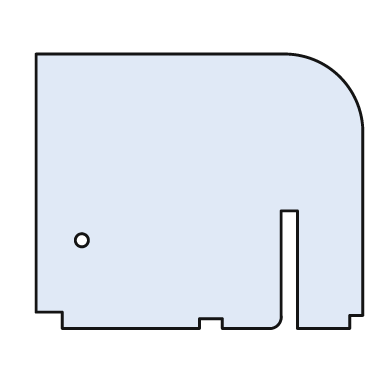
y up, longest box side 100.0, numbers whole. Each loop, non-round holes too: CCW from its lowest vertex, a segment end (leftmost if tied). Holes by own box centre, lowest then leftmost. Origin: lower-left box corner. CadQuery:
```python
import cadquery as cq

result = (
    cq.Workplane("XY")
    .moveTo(8.0, 0.0)
    .lineTo(50.0, 0.0)
    .lineTo(50.0, 3.0)
    .lineTo(57.0, 3.0)
    .lineTo(57.0, 0.0)
    .lineTo(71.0, 0.0)
    .threePointArc((74.0, 1.0), (75.0, 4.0))
    .lineTo(75.0, 36.0)
    .lineTo(80.0, 36.0)
    .lineTo(80.0, 0.0)
    .lineTo(96.0, 0.0)
    .lineTo(96.0, 4.0)
    .lineTo(100.0, 4.0)
    .lineTo(100.0, 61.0)
    .threePointArc((93.0, 77.0), (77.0, 84.0))
    .lineTo(0.0, 84.0)
    .lineTo(0.0, 5.0)
    .lineTo(8.0, 5.0)
    .close()
    .moveTo(14.0, 27.0)
    .circle(2.0)
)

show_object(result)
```